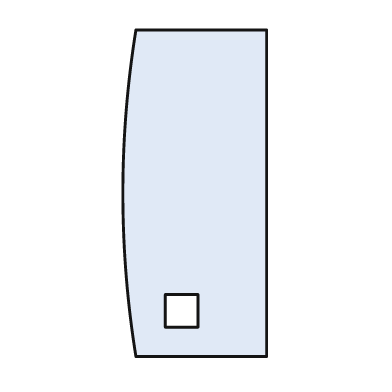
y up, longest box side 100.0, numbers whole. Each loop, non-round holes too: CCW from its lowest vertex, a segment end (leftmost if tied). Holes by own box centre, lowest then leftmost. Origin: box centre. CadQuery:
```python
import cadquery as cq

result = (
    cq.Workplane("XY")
    .moveTo(-18.0, -50.0)
    .lineTo(22.0, -50.0)
    .lineTo(22.0, 50.0)
    .lineTo(-18.0, 50.0)
    .threePointArc((-22.0, 0.0), (-18.0, -50.0))
    .close()
    .moveTo(-9.0, -41.0)
    .lineTo(1.0, -41.0)
    .lineTo(1.0, -31.0)
    .lineTo(-9.0, -31.0)
    .close()
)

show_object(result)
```